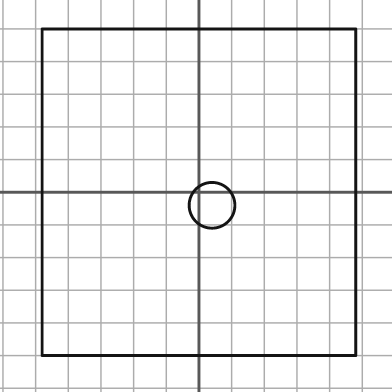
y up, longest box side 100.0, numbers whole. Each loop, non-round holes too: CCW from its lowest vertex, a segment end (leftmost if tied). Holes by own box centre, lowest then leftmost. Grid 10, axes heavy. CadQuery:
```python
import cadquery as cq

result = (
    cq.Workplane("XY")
    .moveTo(-48.0, -50.0)
    .lineTo(48.0, -50.0)
    .lineTo(48.0, 50.0)
    .lineTo(-48.0, 50.0)
    .close()
    .moveTo(4.0, -4.0)
    .circle(7.0)
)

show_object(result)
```